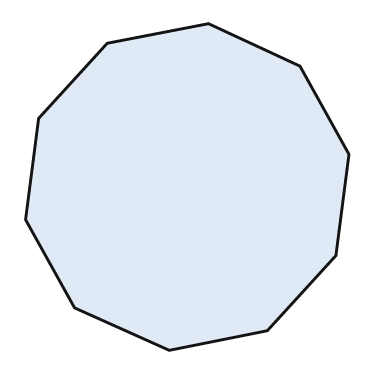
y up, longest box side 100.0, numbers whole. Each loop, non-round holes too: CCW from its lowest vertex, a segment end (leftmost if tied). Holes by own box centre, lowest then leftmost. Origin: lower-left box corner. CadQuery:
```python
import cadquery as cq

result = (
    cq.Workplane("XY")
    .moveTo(44.0, 0.0)
    .lineTo(74.0, 6.0)
    .lineTo(95.0, 29.0)
    .lineTo(99.0, 60.0)
    .lineTo(84.0, 87.0)
    .lineTo(56.0, 100.0)
    .lineTo(25.0, 94.0)
    .lineTo(4.0, 71.0)
    .lineTo(0.0, 40.0)
    .lineTo(15.0, 13.0)
    .close()
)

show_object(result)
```